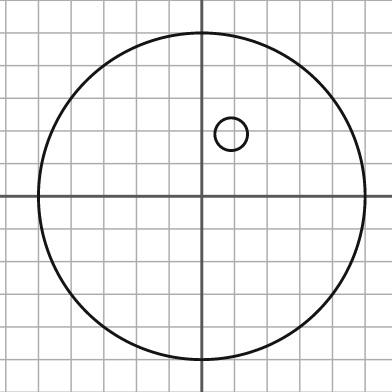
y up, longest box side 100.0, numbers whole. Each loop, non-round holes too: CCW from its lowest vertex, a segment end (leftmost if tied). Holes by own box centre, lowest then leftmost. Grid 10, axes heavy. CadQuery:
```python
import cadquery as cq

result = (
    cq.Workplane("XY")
    .moveTo(0.0, 0.0)
    .circle(50.0)
    .moveTo(9.0, 19.0)
    .circle(5.0)
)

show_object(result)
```